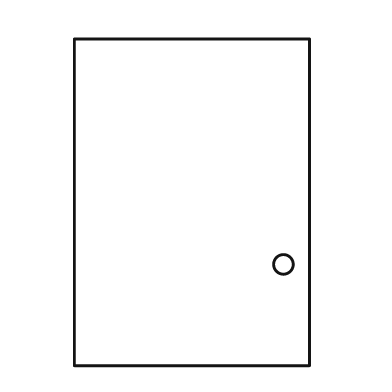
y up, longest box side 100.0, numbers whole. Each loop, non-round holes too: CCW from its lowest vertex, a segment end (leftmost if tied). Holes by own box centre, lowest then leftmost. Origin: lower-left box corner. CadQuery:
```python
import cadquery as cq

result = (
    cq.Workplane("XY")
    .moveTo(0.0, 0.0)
    .lineTo(72.0, 0.0)
    .lineTo(72.0, 100.0)
    .lineTo(0.0, 100.0)
    .close()
    .moveTo(64.0, 31.0)
    .circle(3.0)
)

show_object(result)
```